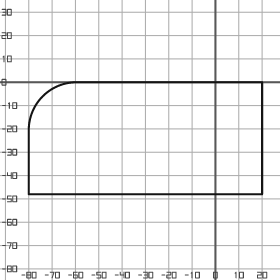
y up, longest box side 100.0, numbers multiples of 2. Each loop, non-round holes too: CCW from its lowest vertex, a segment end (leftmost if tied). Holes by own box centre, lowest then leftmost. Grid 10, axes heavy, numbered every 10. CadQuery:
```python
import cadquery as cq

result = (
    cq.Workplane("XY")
    .moveTo(-80.0, -48.0)
    .lineTo(20.0, -48.0)
    .lineTo(20.0, 0.0)
    .lineTo(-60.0, 0.0)
    .threePointArc((-74.0, -6.0), (-80.0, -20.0))
    .close()
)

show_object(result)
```